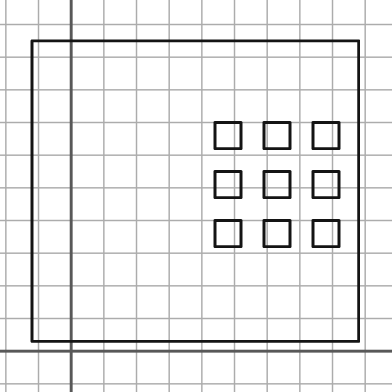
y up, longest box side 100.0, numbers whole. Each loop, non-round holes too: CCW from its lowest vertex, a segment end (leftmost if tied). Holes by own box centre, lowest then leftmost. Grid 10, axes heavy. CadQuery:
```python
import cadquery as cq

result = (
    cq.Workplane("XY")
    .moveTo(-12.0, 3.0)
    .lineTo(88.0, 3.0)
    .lineTo(88.0, 95.0)
    .lineTo(-12.0, 95.0)
    .close()
    .moveTo(44.0, 32.0)
    .lineTo(52.0, 32.0)
    .lineTo(52.0, 40.0)
    .lineTo(44.0, 40.0)
    .close()
    .moveTo(59.0, 32.0)
    .lineTo(67.0, 32.0)
    .lineTo(67.0, 40.0)
    .lineTo(59.0, 40.0)
    .close()
    .moveTo(74.0, 32.0)
    .lineTo(82.0, 32.0)
    .lineTo(82.0, 40.0)
    .lineTo(74.0, 40.0)
    .close()
    .moveTo(44.0, 47.0)
    .lineTo(52.0, 47.0)
    .lineTo(52.0, 55.0)
    .lineTo(44.0, 55.0)
    .close()
    .moveTo(59.0, 47.0)
    .lineTo(67.0, 47.0)
    .lineTo(67.0, 55.0)
    .lineTo(59.0, 55.0)
    .close()
    .moveTo(74.0, 47.0)
    .lineTo(82.0, 47.0)
    .lineTo(82.0, 55.0)
    .lineTo(74.0, 55.0)
    .close()
    .moveTo(44.0, 62.0)
    .lineTo(52.0, 62.0)
    .lineTo(52.0, 70.0)
    .lineTo(44.0, 70.0)
    .close()
    .moveTo(59.0, 62.0)
    .lineTo(67.0, 62.0)
    .lineTo(67.0, 70.0)
    .lineTo(59.0, 70.0)
    .close()
    .moveTo(74.0, 62.0)
    .lineTo(82.0, 62.0)
    .lineTo(82.0, 70.0)
    .lineTo(74.0, 70.0)
    .close()
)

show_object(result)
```